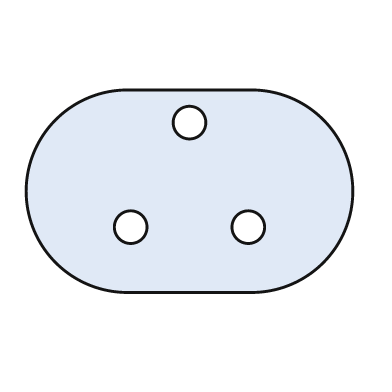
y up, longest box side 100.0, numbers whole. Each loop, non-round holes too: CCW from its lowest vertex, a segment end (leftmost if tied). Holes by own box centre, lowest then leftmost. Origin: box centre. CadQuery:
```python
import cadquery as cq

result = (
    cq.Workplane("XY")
    .moveTo(-19.0, -31.0)
    .lineTo(19.0, -31.0)
    .threePointArc((50.0, 0.0), (19.0, 31.0))
    .lineTo(-19.0, 31.0)
    .threePointArc((-50.0, 0.0), (-19.0, -31.0))
    .close()
    .moveTo(-18.0, -11.0)
    .circle(5.0)
    .moveTo(18.0, -11.0)
    .circle(5.0)
    .moveTo(0.0, 21.0)
    .circle(5.0)
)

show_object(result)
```